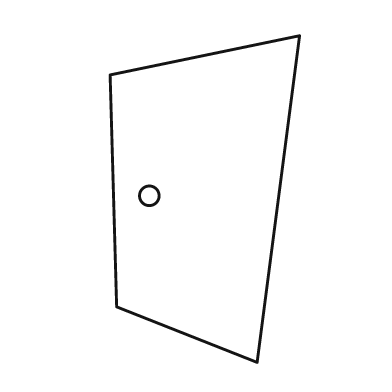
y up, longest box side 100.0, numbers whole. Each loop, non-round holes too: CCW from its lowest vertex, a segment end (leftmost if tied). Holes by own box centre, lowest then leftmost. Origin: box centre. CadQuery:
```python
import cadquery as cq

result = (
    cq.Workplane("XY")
    .moveTo(16.0, -50.0)
    .lineTo(29.0, 50.0)
    .lineTo(-29.0, 38.0)
    .lineTo(-27.0, -33.0)
    .close()
    .moveTo(-17.0, 1.0)
    .circle(3.0)
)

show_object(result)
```